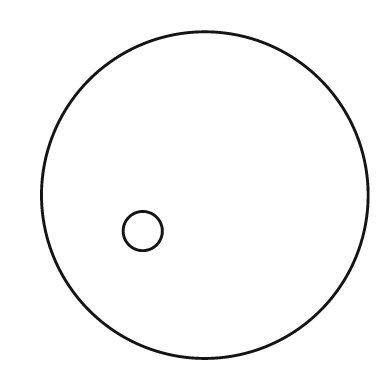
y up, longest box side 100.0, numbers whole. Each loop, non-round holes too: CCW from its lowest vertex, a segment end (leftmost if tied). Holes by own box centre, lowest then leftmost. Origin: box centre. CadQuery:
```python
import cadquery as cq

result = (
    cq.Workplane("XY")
    .moveTo(0.0, 0.0)
    .circle(50.0)
    .moveTo(-19.0, -11.0)
    .circle(6.0)
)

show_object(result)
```